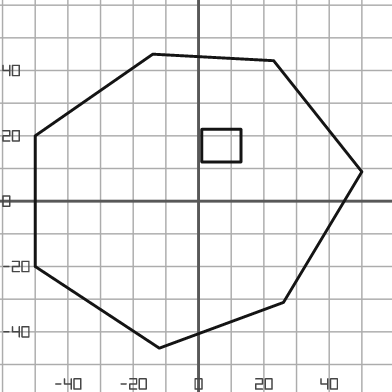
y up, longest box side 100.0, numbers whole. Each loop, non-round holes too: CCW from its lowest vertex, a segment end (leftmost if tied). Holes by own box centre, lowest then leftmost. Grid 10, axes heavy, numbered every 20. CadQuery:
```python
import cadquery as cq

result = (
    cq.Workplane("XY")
    .moveTo(-12.0, -45.0)
    .lineTo(26.0, -31.0)
    .lineTo(50.0, 9.0)
    .lineTo(23.0, 43.0)
    .lineTo(-14.0, 45.0)
    .lineTo(-50.0, 20.0)
    .lineTo(-50.0, -20.0)
    .close()
    .moveTo(1.0, 12.0)
    .lineTo(13.0, 12.0)
    .lineTo(13.0, 22.0)
    .lineTo(1.0, 22.0)
    .close()
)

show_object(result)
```